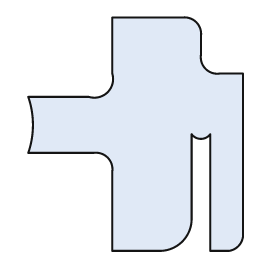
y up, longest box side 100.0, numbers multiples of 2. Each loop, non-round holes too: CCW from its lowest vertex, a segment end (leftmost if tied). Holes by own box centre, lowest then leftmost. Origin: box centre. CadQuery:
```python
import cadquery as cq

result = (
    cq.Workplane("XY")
    .moveTo(-10.0, -50.0)
    .lineTo(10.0, -50.0)
    .threePointArc((20.0, -46.0), (24.0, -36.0))
    .lineTo(24.0, 0.0)
    .threePointArc((28.0, -2.0), (32.0, 0.0))
    .lineTo(32.0, -50.0)
    .lineTo(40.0, -50.0)
    .threePointArc((44.0, -48.0), (46.0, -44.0))
    .lineTo(46.0, 26.0)
    .lineTo(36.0, 26.0)
    .threePointArc((30.0, 28.0), (28.0, 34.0))
    .lineTo(28.0, 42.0)
    .threePointArc((26.0, 48.0), (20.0, 50.0))
    .lineTo(-10.0, 50.0)
    .lineTo(-10.0, 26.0)
    .threePointArc((-12.0, 18.0), (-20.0, 16.0))
    .lineTo(-46.0, 16.0)
    .threePointArc((-44.0, 4.0), (-46.0, -8.0))
    .lineTo(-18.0, -8.0)
    .threePointArc((-12.0, -10.0), (-10.0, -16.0))
    .close()
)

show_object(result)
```